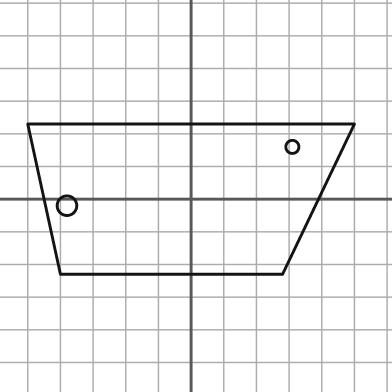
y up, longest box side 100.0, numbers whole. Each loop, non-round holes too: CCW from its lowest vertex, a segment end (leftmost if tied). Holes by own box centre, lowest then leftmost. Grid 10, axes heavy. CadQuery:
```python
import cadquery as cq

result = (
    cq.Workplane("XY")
    .moveTo(-40.0, -23.0)
    .lineTo(28.0, -23.0)
    .lineTo(50.0, 23.0)
    .lineTo(-50.0, 23.0)
    .close()
    .moveTo(-38.0, -2.0)
    .circle(3.0)
    .moveTo(31.0, 16.0)
    .circle(2.0)
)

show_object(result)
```